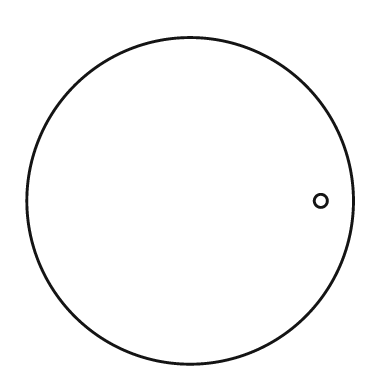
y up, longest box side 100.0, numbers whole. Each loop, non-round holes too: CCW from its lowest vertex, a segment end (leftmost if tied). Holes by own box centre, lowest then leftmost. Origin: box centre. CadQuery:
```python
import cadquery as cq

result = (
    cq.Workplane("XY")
    .moveTo(0.0, 0.0)
    .circle(50.0)
    .moveTo(40.0, 0.0)
    .circle(2.0)
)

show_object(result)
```